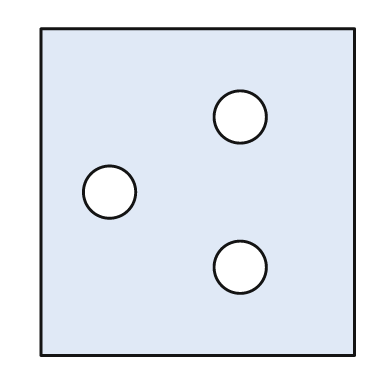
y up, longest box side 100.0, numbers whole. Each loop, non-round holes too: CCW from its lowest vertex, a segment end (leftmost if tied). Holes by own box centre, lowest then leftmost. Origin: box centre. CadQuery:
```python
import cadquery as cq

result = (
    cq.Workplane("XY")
    .moveTo(-48.0, -50.0)
    .lineTo(48.0, -50.0)
    .lineTo(48.0, 50.0)
    .lineTo(-48.0, 50.0)
    .close()
    .moveTo(13.0, -23.0)
    .circle(8.0)
    .moveTo(-27.0, 0.0)
    .circle(8.0)
    .moveTo(13.0, 23.0)
    .circle(8.0)
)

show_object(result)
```